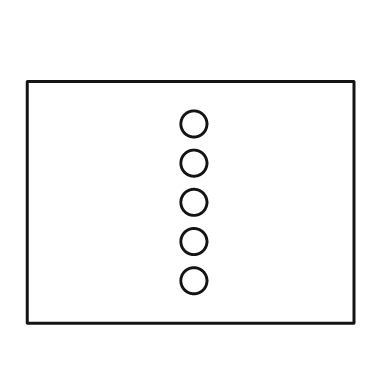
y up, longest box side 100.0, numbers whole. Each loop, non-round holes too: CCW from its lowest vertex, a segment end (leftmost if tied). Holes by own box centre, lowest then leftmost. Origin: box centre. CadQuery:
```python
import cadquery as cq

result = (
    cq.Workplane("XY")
    .moveTo(-50.0, -37.0)
    .lineTo(50.0, -37.0)
    .lineTo(50.0, 37.0)
    .lineTo(-50.0, 37.0)
    .close()
    .moveTo(1.0, -24.0)
    .circle(4.0)
    .moveTo(1.0, -12.0)
    .circle(4.0)
    .moveTo(1.0, 0.0)
    .circle(4.0)
    .moveTo(1.0, 12.0)
    .circle(4.0)
    .moveTo(1.0, 24.0)
    .circle(4.0)
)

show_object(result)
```